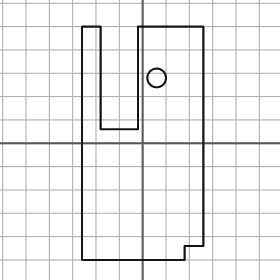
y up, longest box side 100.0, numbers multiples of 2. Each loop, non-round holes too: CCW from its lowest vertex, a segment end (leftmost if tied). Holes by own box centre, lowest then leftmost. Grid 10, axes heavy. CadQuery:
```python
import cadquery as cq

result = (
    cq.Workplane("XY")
    .moveTo(-26.0, -50.0)
    .lineTo(18.0, -50.0)
    .lineTo(18.0, -44.0)
    .lineTo(26.0, -44.0)
    .lineTo(26.0, 50.0)
    .lineTo(-2.0, 50.0)
    .lineTo(-2.0, 6.0)
    .lineTo(-18.0, 6.0)
    .lineTo(-18.0, 50.0)
    .lineTo(-26.0, 50.0)
    .close()
    .moveTo(6.0, 28.0)
    .circle(4.0)
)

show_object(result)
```